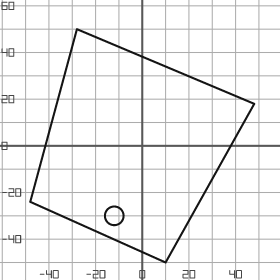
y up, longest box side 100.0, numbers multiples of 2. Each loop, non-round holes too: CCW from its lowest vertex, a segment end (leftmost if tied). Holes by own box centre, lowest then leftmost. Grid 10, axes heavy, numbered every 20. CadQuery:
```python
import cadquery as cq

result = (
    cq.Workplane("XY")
    .moveTo(10.0, -50.0)
    .lineTo(48.0, 18.0)
    .lineTo(-28.0, 50.0)
    .lineTo(-48.0, -24.0)
    .close()
    .moveTo(-12.0, -30.0)
    .circle(4.0)
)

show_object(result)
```